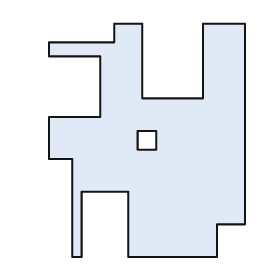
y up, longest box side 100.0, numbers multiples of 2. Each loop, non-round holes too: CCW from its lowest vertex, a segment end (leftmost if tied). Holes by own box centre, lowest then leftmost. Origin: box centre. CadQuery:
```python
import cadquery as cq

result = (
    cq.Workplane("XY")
    .moveTo(-32.0, -50.0)
    .lineTo(-28.0, -50.0)
    .lineTo(-28.0, -22.0)
    .lineTo(-8.0, -22.0)
    .lineTo(-8.0, -50.0)
    .lineTo(30.0, -50.0)
    .lineTo(30.0, -36.0)
    .lineTo(42.0, -36.0)
    .lineTo(42.0, 50.0)
    .lineTo(24.0, 50.0)
    .lineTo(24.0, 18.0)
    .lineTo(-2.0, 18.0)
    .lineTo(-2.0, 50.0)
    .lineTo(-14.0, 50.0)
    .lineTo(-14.0, 42.0)
    .lineTo(-42.0, 42.0)
    .lineTo(-42.0, 36.0)
    .lineTo(-20.0, 36.0)
    .lineTo(-20.0, 10.0)
    .lineTo(-42.0, 10.0)
    .lineTo(-42.0, -8.0)
    .lineTo(-32.0, -8.0)
    .close()
    .moveTo(-4.0, -4.0)
    .lineTo(4.0, -4.0)
    .lineTo(4.0, 4.0)
    .lineTo(-4.0, 4.0)
    .close()
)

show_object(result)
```